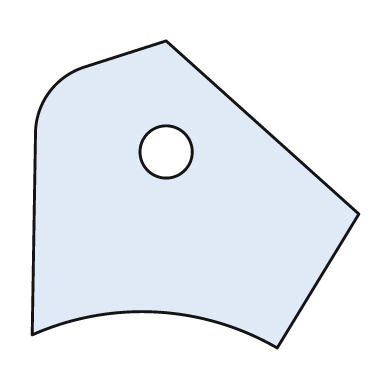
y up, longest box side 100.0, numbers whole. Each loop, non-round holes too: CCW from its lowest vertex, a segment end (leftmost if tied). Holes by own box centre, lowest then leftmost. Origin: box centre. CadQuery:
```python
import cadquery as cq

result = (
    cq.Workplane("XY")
    .moveTo(25.0, -47.0)
    .lineTo(50.0, -6.0)
    .lineTo(-9.0, 47.0)
    .lineTo(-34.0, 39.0)
    .threePointArc((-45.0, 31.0), (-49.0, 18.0))
    .lineTo(-50.0, -43.0)
    .threePointArc((-12.0, -36.0), (25.0, -47.0))
    .close()
    .moveTo(-9.0, 13.0)
    .circle(8.0)
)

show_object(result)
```